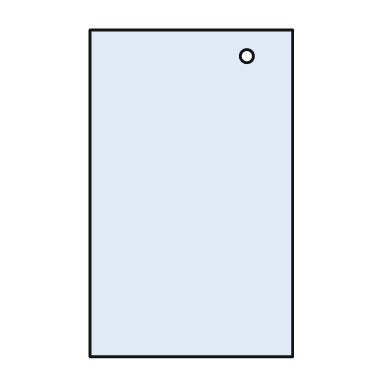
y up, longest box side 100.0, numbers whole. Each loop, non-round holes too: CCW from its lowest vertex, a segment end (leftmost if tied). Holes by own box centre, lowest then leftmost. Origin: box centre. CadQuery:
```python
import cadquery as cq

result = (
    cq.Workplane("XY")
    .moveTo(-31.0, -50.0)
    .lineTo(31.0, -50.0)
    .lineTo(31.0, 50.0)
    .lineTo(-31.0, 50.0)
    .close()
    .moveTo(17.0, 42.0)
    .circle(2.0)
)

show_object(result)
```